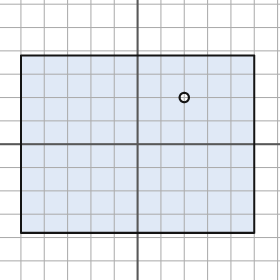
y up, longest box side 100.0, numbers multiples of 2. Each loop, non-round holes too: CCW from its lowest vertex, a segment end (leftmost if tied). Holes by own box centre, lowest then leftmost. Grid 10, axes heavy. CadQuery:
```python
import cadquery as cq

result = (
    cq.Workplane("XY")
    .moveTo(-50.0, -38.0)
    .lineTo(50.0, -38.0)
    .lineTo(50.0, 38.0)
    .lineTo(-50.0, 38.0)
    .close()
    .moveTo(20.0, 20.0)
    .circle(2.0)
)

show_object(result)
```